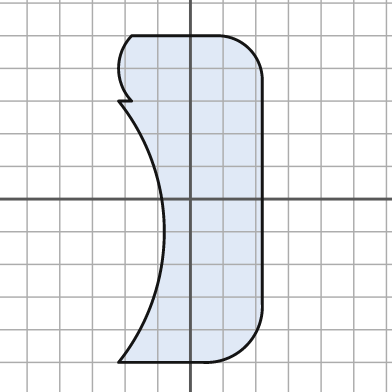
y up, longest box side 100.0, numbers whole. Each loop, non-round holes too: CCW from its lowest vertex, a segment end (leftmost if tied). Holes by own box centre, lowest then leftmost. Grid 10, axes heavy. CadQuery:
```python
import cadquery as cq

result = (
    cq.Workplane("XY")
    .moveTo(-22.0, -50.0)
    .lineTo(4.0, -50.0)
    .threePointArc((17.0, -45.0), (22.0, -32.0))
    .lineTo(22.0, 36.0)
    .threePointArc((18.0, 46.0), (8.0, 50.0))
    .lineTo(-18.0, 50.0)
    .threePointArc((-22.0, 40.0), (-18.0, 30.0))
    .lineTo(-22.0, 30.0)
    .threePointArc((-8.0, -10.0), (-22.0, -50.0))
    .close()
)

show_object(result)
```